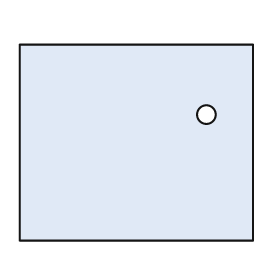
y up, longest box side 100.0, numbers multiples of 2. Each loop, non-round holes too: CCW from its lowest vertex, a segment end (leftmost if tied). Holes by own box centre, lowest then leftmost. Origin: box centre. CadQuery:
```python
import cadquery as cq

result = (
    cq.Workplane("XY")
    .moveTo(-50.0, -42.0)
    .lineTo(50.0, -42.0)
    .lineTo(50.0, 42.0)
    .lineTo(-50.0, 42.0)
    .close()
    .moveTo(30.0, 12.0)
    .circle(4.0)
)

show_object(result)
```